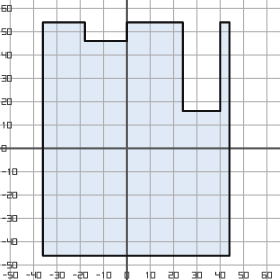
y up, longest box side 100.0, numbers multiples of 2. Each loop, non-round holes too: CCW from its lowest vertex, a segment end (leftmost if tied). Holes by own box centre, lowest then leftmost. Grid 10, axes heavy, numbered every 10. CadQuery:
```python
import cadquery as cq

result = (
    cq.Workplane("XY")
    .moveTo(-36.0, -46.0)
    .lineTo(44.0, -46.0)
    .lineTo(44.0, 54.0)
    .lineTo(40.0, 54.0)
    .lineTo(40.0, 16.0)
    .lineTo(24.0, 16.0)
    .lineTo(24.0, 54.0)
    .lineTo(0.0, 54.0)
    .lineTo(0.0, 46.0)
    .lineTo(-18.0, 46.0)
    .lineTo(-18.0, 54.0)
    .lineTo(-36.0, 54.0)
    .close()
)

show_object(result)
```